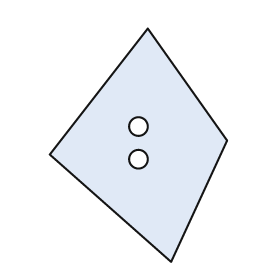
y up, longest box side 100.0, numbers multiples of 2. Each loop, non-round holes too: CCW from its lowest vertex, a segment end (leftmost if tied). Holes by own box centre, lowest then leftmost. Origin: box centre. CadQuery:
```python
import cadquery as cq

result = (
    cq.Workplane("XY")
    .moveTo(14.0, -50.0)
    .lineTo(38.0, 2.0)
    .lineTo(4.0, 50.0)
    .lineTo(-38.0, -4.0)
    .close()
    .moveTo(0.0, -6.0)
    .circle(4.0)
    .moveTo(0.0, 8.0)
    .circle(4.0)
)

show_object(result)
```